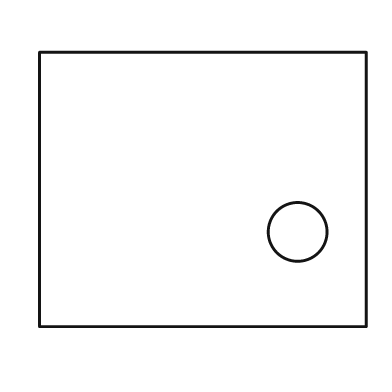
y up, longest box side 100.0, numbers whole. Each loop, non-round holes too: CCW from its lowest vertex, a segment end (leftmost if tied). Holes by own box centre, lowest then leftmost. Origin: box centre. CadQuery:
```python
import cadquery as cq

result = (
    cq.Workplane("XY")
    .moveTo(-50.0, -42.0)
    .lineTo(50.0, -42.0)
    .lineTo(50.0, 42.0)
    .lineTo(-50.0, 42.0)
    .close()
    .moveTo(29.0, -13.0)
    .circle(9.0)
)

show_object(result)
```